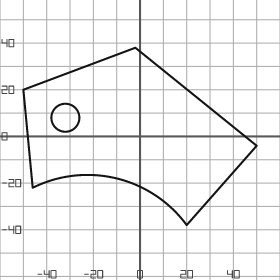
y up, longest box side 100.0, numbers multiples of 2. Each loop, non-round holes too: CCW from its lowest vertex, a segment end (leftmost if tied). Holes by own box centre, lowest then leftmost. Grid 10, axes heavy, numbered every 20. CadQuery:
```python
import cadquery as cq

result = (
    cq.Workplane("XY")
    .moveTo(20.0, -38.0)
    .lineTo(50.0, -4.0)
    .lineTo(-2.0, 38.0)
    .lineTo(-50.0, 20.0)
    .lineTo(-46.0, -22.0)
    .threePointArc((-10.0, -18.0), (20.0, -38.0))
    .close()
    .moveTo(-32.0, 8.0)
    .circle(6.0)
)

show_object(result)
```